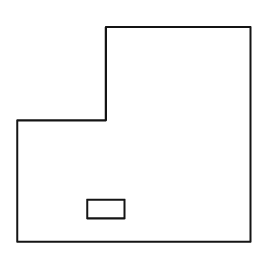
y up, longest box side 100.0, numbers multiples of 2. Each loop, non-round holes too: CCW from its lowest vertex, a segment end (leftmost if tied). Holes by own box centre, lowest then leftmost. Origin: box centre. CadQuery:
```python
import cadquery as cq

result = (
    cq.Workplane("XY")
    .moveTo(-50.0, -46.0)
    .lineTo(50.0, -46.0)
    .lineTo(50.0, 46.0)
    .lineTo(-12.0, 46.0)
    .lineTo(-12.0, 6.0)
    .lineTo(-50.0, 6.0)
    .close()
    .moveTo(-20.0, -36.0)
    .lineTo(-4.0, -36.0)
    .lineTo(-4.0, -28.0)
    .lineTo(-20.0, -28.0)
    .close()
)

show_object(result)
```